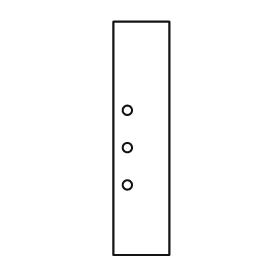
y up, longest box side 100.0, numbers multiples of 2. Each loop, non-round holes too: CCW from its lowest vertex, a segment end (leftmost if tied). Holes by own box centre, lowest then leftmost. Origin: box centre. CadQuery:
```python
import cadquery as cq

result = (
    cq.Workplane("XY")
    .moveTo(-12.0, -50.0)
    .lineTo(12.0, -50.0)
    .lineTo(12.0, 50.0)
    .lineTo(-12.0, 50.0)
    .close()
    .moveTo(-6.0, -20.0)
    .circle(2.0)
    .moveTo(-6.0, -4.0)
    .circle(2.0)
    .moveTo(-6.0, 12.0)
    .circle(2.0)
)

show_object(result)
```